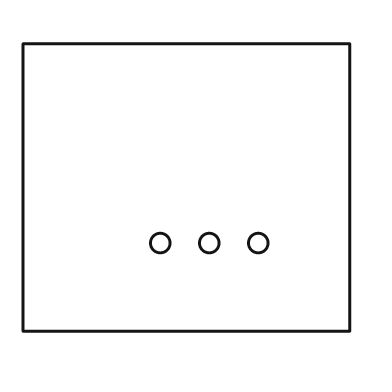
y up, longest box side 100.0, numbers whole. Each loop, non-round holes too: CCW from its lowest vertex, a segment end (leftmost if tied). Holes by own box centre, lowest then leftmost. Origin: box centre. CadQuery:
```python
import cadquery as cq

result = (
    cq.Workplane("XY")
    .moveTo(-50.0, -44.0)
    .lineTo(50.0, -44.0)
    .lineTo(50.0, 44.0)
    .lineTo(-50.0, 44.0)
    .close()
    .moveTo(-8.0, -17.0)
    .circle(3.0)
    .moveTo(7.0, -17.0)
    .circle(3.0)
    .moveTo(22.0, -17.0)
    .circle(3.0)
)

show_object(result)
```